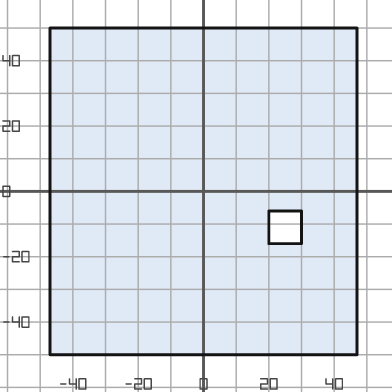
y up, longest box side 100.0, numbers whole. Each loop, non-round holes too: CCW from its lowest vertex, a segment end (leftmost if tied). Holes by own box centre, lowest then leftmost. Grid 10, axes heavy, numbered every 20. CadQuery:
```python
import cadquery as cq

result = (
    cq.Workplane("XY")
    .moveTo(-47.0, -50.0)
    .lineTo(47.0, -50.0)
    .lineTo(47.0, 50.0)
    .lineTo(-47.0, 50.0)
    .close()
    .moveTo(20.0, -16.0)
    .lineTo(30.0, -16.0)
    .lineTo(30.0, -6.0)
    .lineTo(20.0, -6.0)
    .close()
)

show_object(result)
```